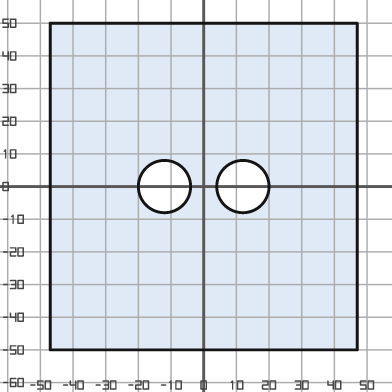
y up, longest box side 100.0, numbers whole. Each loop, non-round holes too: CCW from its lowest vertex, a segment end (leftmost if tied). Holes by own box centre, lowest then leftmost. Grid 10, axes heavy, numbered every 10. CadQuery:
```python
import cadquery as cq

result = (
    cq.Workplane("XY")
    .moveTo(-47.0, -50.0)
    .lineTo(47.0, -50.0)
    .lineTo(47.0, 50.0)
    .lineTo(-47.0, 50.0)
    .close()
    .moveTo(-12.0, 0.0)
    .circle(8.0)
    .moveTo(12.0, 0.0)
    .circle(8.0)
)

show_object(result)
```